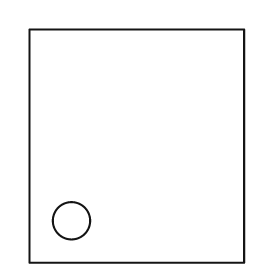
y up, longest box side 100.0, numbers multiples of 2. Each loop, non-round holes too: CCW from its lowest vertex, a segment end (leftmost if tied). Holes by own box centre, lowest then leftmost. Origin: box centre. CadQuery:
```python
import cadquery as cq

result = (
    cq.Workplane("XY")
    .moveTo(-46.0, -50.0)
    .lineTo(46.0, -50.0)
    .lineTo(46.0, 50.0)
    .lineTo(-46.0, 50.0)
    .close()
    .moveTo(-28.0, -32.0)
    .circle(8.0)
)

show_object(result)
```